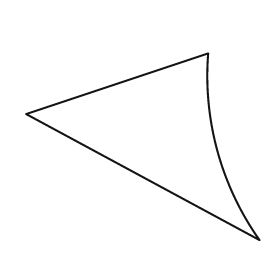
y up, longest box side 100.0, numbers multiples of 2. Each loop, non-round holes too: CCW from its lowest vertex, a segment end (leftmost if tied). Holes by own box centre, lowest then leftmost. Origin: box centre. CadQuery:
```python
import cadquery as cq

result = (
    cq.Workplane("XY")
    .moveTo(50.0, -40.0)
    .threePointArc((32.0, -2.0), (28.0, 40.0))
    .lineTo(-50.0, 14.0)
    .close()
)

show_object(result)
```